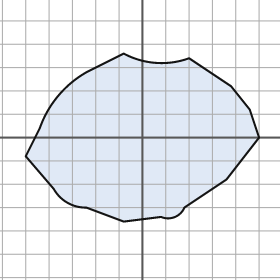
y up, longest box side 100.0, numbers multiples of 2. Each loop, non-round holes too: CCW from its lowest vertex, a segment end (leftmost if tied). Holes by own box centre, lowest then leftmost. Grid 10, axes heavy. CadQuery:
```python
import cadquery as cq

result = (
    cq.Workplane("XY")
    .moveTo(-8.0, -36.0)
    .lineTo(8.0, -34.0)
    .threePointArc((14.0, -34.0), (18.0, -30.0))
    .lineTo(36.0, -18.0)
    .lineTo(50.0, 0.0)
    .lineTo(46.0, 12.0)
    .lineTo(38.0, 22.0)
    .lineTo(20.0, 34.0)
    .threePointArc((6.0, 32.0), (-8.0, 36.0))
    .lineTo(-24.0, 28.0)
    .threePointArc((-36.0, 18.0), (-44.0, 4.0))
    .lineTo(-50.0, -8.0)
    .lineTo(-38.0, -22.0)
    .threePointArc((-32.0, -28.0), (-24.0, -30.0))
    .close()
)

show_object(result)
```